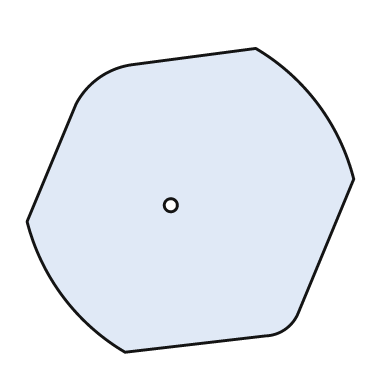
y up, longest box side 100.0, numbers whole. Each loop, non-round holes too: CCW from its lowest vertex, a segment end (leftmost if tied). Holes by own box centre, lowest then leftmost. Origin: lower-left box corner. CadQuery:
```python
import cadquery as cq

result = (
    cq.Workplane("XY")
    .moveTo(30.0, 0.0)
    .lineTo(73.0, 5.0)
    .threePointArc((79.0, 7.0), (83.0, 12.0))
    .lineTo(100.0, 53.0)
    .threePointArc((89.0, 76.0), (70.0, 93.0))
    .lineTo(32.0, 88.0)
    .threePointArc((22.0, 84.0), (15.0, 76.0))
    .lineTo(0.0, 40.0)
    .threePointArc((11.0, 17.0), (30.0, 0.0))
    .close()
    .moveTo(44.0, 45.0)
    .circle(2.0)
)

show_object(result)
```